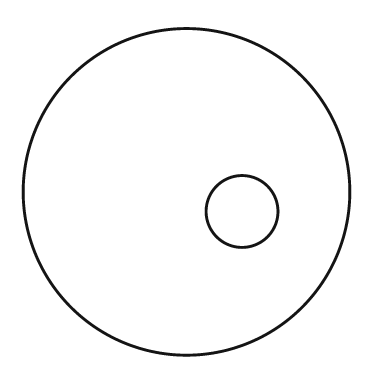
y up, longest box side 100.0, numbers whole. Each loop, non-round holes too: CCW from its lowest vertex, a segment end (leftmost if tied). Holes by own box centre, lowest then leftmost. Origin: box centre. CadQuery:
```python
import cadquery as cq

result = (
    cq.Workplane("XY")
    .moveTo(0.0, 0.0)
    .circle(50.0)
    .moveTo(17.0, -6.0)
    .circle(11.0)
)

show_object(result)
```